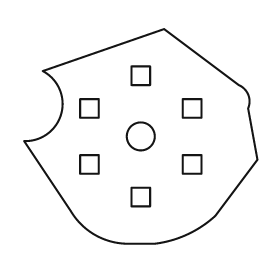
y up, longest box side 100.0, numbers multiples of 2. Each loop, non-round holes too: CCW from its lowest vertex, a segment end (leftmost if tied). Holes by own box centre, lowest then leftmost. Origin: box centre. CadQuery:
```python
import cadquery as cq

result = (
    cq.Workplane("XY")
    .moveTo(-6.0, -46.0)
    .lineTo(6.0, -46.0)
    .threePointArc((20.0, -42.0), (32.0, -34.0))
    .lineTo(50.0, -10.0)
    .lineTo(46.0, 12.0)
    .threePointArc((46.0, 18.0), (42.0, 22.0))
    .lineTo(10.0, 46.0)
    .lineTo(-42.0, 28.0)
    .threePointArc((-34.0, 10.0), (-50.0, -2.0))
    .lineTo(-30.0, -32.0)
    .threePointArc((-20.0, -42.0), (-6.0, -46.0))
    .close()
    .moveTo(-4.0, -30.0)
    .lineTo(4.0, -30.0)
    .lineTo(4.0, -22.0)
    .lineTo(-4.0, -22.0)
    .close()
    .moveTo(-26.0, -16.0)
    .lineTo(-18.0, -16.0)
    .lineTo(-18.0, -8.0)
    .lineTo(-26.0, -8.0)
    .close()
    .moveTo(18.0, -16.0)
    .lineTo(26.0, -16.0)
    .lineTo(26.0, -8.0)
    .lineTo(18.0, -8.0)
    .close()
    .moveTo(0.0, 0.0)
    .circle(6.0)
    .moveTo(-26.0, 8.0)
    .lineTo(-18.0, 8.0)
    .lineTo(-18.0, 16.0)
    .lineTo(-26.0, 16.0)
    .close()
    .moveTo(18.0, 8.0)
    .lineTo(26.0, 8.0)
    .lineTo(26.0, 16.0)
    .lineTo(18.0, 16.0)
    .close()
    .moveTo(-4.0, 22.0)
    .lineTo(4.0, 22.0)
    .lineTo(4.0, 30.0)
    .lineTo(-4.0, 30.0)
    .close()
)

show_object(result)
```